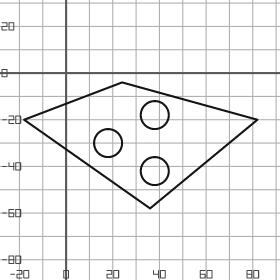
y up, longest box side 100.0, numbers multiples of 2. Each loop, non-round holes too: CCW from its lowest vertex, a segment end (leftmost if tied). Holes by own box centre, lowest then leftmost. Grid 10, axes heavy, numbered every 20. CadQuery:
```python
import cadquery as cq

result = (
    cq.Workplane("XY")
    .moveTo(36.0, -58.0)
    .lineTo(82.0, -20.0)
    .lineTo(24.0, -4.0)
    .lineTo(-18.0, -20.0)
    .close()
    .moveTo(38.0, -42.0)
    .circle(6.0)
    .moveTo(18.0, -30.0)
    .circle(6.0)
    .moveTo(38.0, -18.0)
    .circle(6.0)
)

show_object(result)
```